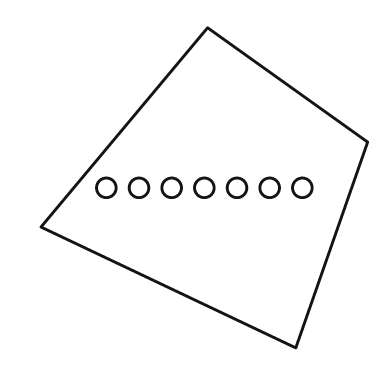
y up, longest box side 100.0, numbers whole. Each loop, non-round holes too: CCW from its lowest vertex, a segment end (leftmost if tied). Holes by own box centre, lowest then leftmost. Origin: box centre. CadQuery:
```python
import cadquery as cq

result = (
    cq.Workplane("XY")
    .moveTo(28.0, -49.0)
    .lineTo(50.0, 14.0)
    .lineTo(1.0, 49.0)
    .lineTo(-50.0, -12.0)
    .close()
    .moveTo(-30.0, 0.0)
    .circle(3.0)
    .moveTo(-20.0, 0.0)
    .circle(3.0)
    .moveTo(-10.0, 0.0)
    .circle(3.0)
    .moveTo(0.0, 0.0)
    .circle(3.0)
    .moveTo(10.0, 0.0)
    .circle(3.0)
    .moveTo(20.0, 0.0)
    .circle(3.0)
    .moveTo(30.0, 0.0)
    .circle(3.0)
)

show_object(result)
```